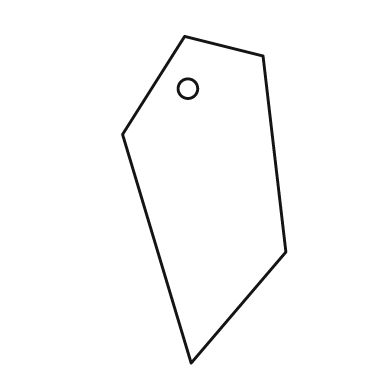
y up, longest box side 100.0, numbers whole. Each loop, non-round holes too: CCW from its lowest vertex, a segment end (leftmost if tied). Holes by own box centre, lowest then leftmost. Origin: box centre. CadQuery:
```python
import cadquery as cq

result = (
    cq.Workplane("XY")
    .moveTo(-4.0, -50.0)
    .lineTo(25.0, -16.0)
    .lineTo(18.0, 44.0)
    .lineTo(-6.0, 50.0)
    .lineTo(-25.0, 20.0)
    .close()
    .moveTo(-5.0, 34.0)
    .circle(3.0)
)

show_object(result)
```